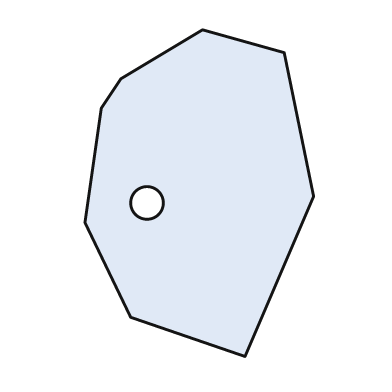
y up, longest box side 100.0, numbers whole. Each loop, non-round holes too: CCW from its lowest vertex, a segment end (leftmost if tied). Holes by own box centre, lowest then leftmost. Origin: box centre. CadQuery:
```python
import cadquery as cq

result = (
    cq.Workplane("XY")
    .moveTo(14.0, -50.0)
    .lineTo(35.0, -1.0)
    .lineTo(26.0, 43.0)
    .lineTo(1.0, 50.0)
    .lineTo(-24.0, 35.0)
    .lineTo(-30.0, 26.0)
    .lineTo(-35.0, -9.0)
    .lineTo(-21.0, -38.0)
    .close()
    .moveTo(-16.0, -3.0)
    .circle(5.0)
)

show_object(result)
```